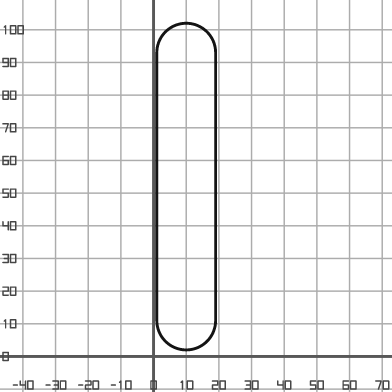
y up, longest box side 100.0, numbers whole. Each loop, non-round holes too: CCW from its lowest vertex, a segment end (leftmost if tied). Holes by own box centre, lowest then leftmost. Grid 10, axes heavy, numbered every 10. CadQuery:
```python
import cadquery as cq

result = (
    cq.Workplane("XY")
    .moveTo(1.0, 11.0)
    .threePointArc((10.0, 2.0), (19.0, 11.0))
    .lineTo(19.0, 93.0)
    .threePointArc((10.0, 102.0), (1.0, 93.0))
    .close()
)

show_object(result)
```